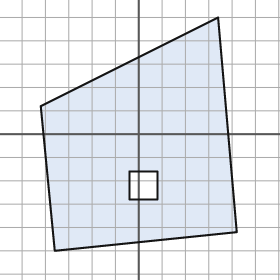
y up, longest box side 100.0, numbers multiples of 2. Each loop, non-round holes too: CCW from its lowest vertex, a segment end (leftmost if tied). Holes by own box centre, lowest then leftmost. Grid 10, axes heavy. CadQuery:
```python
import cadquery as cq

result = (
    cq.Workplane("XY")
    .moveTo(-36.0, -50.0)
    .lineTo(42.0, -42.0)
    .lineTo(34.0, 50.0)
    .lineTo(-42.0, 12.0)
    .close()
    .moveTo(-4.0, -28.0)
    .lineTo(8.0, -28.0)
    .lineTo(8.0, -16.0)
    .lineTo(-4.0, -16.0)
    .close()
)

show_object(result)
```